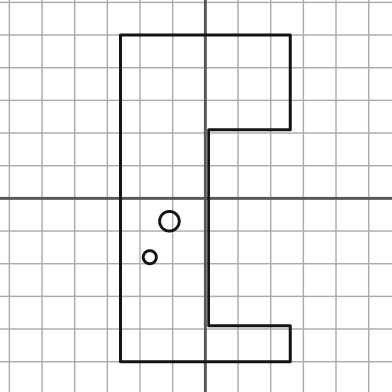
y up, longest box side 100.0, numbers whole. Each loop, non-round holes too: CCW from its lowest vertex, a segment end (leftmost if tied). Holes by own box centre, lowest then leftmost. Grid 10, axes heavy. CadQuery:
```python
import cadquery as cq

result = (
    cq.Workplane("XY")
    .moveTo(-26.0, -50.0)
    .lineTo(26.0, -50.0)
    .lineTo(26.0, -39.0)
    .lineTo(1.0, -39.0)
    .lineTo(1.0, 21.0)
    .lineTo(26.0, 21.0)
    .lineTo(26.0, 50.0)
    .lineTo(-26.0, 50.0)
    .close()
    .moveTo(-17.0, -18.0)
    .circle(2.0)
    .moveTo(-11.0, -7.0)
    .circle(3.0)
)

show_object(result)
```